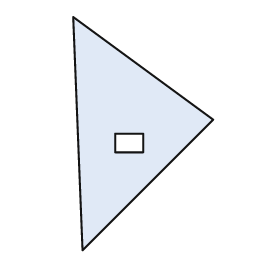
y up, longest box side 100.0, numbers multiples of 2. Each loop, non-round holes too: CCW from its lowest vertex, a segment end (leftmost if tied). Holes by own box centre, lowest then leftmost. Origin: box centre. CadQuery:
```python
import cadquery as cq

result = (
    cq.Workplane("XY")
    .moveTo(-26.0, -50.0)
    .lineTo(30.0, 6.0)
    .lineTo(-30.0, 50.0)
    .close()
    .moveTo(-12.0, -8.0)
    .lineTo(0.0, -8.0)
    .lineTo(0.0, 0.0)
    .lineTo(-12.0, 0.0)
    .close()
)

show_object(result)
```